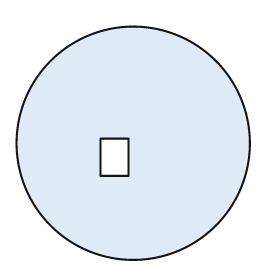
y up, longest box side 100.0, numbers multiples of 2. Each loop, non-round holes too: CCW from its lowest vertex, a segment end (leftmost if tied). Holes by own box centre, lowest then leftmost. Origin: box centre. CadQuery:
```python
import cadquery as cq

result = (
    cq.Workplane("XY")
    .moveTo(0.0, 0.0)
    .circle(50.0)
    .moveTo(-14.0, -14.0)
    .lineTo(-2.0, -14.0)
    .lineTo(-2.0, 2.0)
    .lineTo(-14.0, 2.0)
    .close()
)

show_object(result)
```